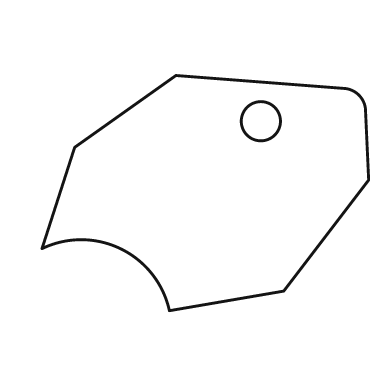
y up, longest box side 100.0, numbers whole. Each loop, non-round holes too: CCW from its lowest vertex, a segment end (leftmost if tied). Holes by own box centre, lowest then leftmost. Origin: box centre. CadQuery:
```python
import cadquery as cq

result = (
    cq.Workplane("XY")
    .moveTo(-11.0, -36.0)
    .lineTo(24.0, -30.0)
    .lineTo(50.0, 4.0)
    .lineTo(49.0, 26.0)
    .threePointArc((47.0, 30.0), (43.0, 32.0))
    .lineTo(-9.0, 36.0)
    .lineTo(-40.0, 14.0)
    .lineTo(-50.0, -17.0)
    .threePointArc((-26.0, -17.0), (-11.0, -36.0))
    .close()
    .moveTo(17.0, 22.0)
    .circle(6.0)
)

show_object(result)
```